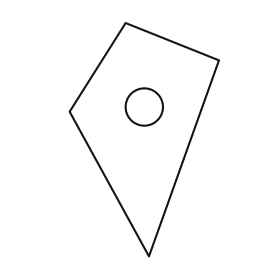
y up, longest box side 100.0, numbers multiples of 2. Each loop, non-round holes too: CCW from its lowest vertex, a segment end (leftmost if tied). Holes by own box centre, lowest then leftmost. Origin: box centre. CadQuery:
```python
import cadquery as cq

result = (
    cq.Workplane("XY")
    .moveTo(2.0, -50.0)
    .lineTo(32.0, 34.0)
    .lineTo(-8.0, 50.0)
    .lineTo(-32.0, 12.0)
    .close()
    .moveTo(0.0, 14.0)
    .circle(8.0)
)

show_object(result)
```